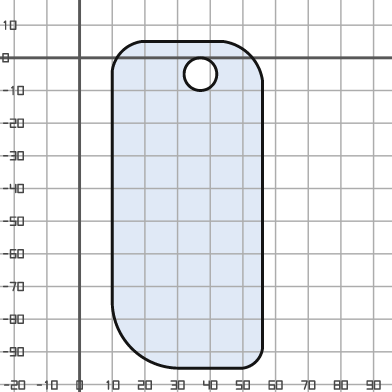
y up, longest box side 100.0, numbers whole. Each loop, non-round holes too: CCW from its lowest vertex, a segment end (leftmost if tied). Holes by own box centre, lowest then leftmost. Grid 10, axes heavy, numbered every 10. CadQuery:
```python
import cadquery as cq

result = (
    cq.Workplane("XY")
    .moveTo(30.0, -95.0)
    .lineTo(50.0, -95.0)
    .threePointArc((54.0, -93.0), (56.0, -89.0))
    .lineTo(56.0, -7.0)
    .threePointArc((52.0, 1.0), (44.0, 5.0))
    .lineTo(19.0, 5.0)
    .threePointArc((13.0, 2.0), (10.0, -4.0))
    .lineTo(10.0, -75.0)
    .threePointArc((16.0, -89.0), (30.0, -95.0))
    .close()
    .moveTo(37.0, -5.0)
    .circle(5.0)
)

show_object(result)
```